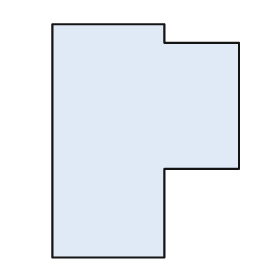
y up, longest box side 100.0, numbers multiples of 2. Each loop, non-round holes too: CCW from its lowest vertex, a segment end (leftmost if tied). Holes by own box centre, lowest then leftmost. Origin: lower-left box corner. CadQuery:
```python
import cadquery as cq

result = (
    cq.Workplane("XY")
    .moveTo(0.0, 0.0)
    .lineTo(48.0, 0.0)
    .lineTo(48.0, 38.0)
    .lineTo(80.0, 38.0)
    .lineTo(80.0, 92.0)
    .lineTo(48.0, 92.0)
    .lineTo(48.0, 100.0)
    .lineTo(0.0, 100.0)
    .close()
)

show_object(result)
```